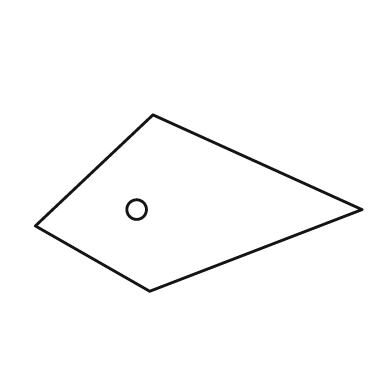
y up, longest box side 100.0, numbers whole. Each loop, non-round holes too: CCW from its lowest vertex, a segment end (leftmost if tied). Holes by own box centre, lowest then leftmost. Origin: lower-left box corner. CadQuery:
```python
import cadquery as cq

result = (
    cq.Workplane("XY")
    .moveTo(35.0, 0.0)
    .lineTo(100.0, 25.0)
    .lineTo(36.0, 54.0)
    .lineTo(0.0, 20.0)
    .close()
    .moveTo(31.0, 25.0)
    .circle(3.0)
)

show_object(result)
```